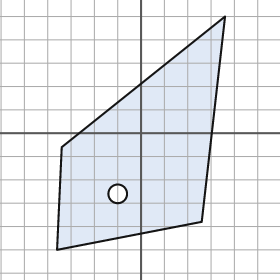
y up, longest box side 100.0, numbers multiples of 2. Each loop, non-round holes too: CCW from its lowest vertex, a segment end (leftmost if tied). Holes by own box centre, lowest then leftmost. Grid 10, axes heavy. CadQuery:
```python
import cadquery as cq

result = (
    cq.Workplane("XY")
    .moveTo(-36.0, -50.0)
    .lineTo(26.0, -38.0)
    .lineTo(36.0, 50.0)
    .lineTo(-34.0, -6.0)
    .close()
    .moveTo(-10.0, -26.0)
    .circle(4.0)
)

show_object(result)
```